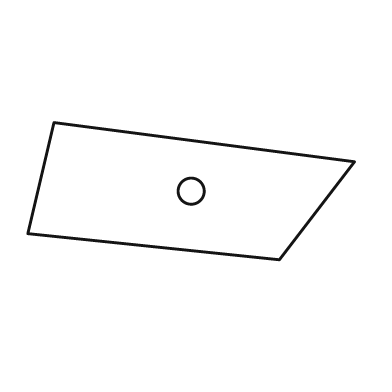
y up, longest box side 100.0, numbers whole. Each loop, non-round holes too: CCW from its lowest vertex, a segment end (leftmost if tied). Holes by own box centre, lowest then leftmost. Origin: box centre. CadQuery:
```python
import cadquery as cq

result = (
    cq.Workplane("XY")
    .moveTo(27.0, -21.0)
    .lineTo(50.0, 9.0)
    .lineTo(-42.0, 21.0)
    .lineTo(-50.0, -13.0)
    .close()
    .moveTo(0.0, 0.0)
    .circle(4.0)
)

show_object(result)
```